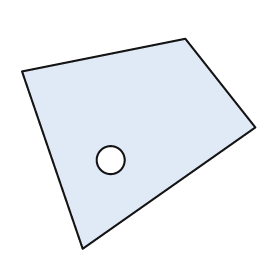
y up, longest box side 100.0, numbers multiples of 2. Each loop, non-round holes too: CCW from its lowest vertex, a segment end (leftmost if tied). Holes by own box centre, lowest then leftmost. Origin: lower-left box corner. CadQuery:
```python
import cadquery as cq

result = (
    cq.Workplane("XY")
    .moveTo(26.0, 0.0)
    .lineTo(100.0, 52.0)
    .lineTo(70.0, 90.0)
    .lineTo(0.0, 76.0)
    .close()
    .moveTo(38.0, 38.0)
    .circle(6.0)
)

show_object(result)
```